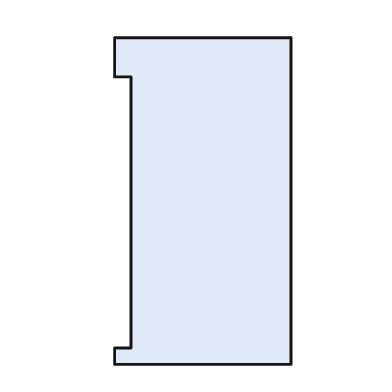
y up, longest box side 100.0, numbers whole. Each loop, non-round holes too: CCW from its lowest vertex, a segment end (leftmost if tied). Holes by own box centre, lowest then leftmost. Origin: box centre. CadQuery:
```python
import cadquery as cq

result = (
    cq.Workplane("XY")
    .moveTo(-27.0, -50.0)
    .lineTo(27.0, -50.0)
    .lineTo(27.0, 50.0)
    .lineTo(-27.0, 50.0)
    .lineTo(-27.0, 38.0)
    .lineTo(-22.0, 38.0)
    .lineTo(-22.0, -45.0)
    .lineTo(-27.0, -45.0)
    .close()
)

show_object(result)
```